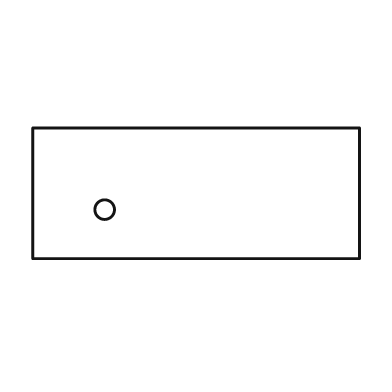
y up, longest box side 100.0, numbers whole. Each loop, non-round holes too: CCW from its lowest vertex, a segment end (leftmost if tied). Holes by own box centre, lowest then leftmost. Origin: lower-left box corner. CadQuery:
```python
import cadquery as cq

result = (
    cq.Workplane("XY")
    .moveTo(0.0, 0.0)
    .lineTo(100.0, 0.0)
    .lineTo(100.0, 40.0)
    .lineTo(0.0, 40.0)
    .close()
    .moveTo(22.0, 15.0)
    .circle(3.0)
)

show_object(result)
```